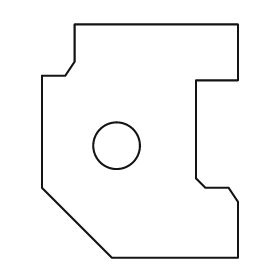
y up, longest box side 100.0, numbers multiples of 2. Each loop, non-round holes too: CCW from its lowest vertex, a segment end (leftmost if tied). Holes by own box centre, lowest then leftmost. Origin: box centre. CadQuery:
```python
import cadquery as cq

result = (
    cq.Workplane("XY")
    .moveTo(-12.0, -50.0)
    .lineTo(42.0, -50.0)
    .lineTo(42.0, -26.0)
    .lineTo(38.0, -20.0)
    .lineTo(28.0, -20.0)
    .lineTo(24.0, -16.0)
    .lineTo(24.0, 26.0)
    .lineTo(42.0, 26.0)
    .lineTo(42.0, 50.0)
    .lineTo(-28.0, 50.0)
    .lineTo(-28.0, 34.0)
    .lineTo(-32.0, 28.0)
    .lineTo(-42.0, 28.0)
    .lineTo(-42.0, -20.0)
    .close()
    .moveTo(-10.0, -2.0)
    .circle(10.0)
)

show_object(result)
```